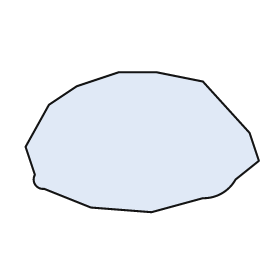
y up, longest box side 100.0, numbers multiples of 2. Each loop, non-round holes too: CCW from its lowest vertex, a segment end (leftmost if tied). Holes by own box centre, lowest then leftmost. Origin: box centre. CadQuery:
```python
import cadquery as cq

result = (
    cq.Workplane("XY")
    .moveTo(4.0, -30.0)
    .lineTo(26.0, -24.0)
    .threePointArc((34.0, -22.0), (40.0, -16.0))
    .lineTo(50.0, -8.0)
    .lineTo(46.0, 4.0)
    .lineTo(26.0, 26.0)
    .lineTo(6.0, 30.0)
    .lineTo(-10.0, 30.0)
    .lineTo(-28.0, 24.0)
    .lineTo(-40.0, 16.0)
    .lineTo(-50.0, -2.0)
    .lineTo(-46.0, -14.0)
    .threePointArc((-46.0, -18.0), (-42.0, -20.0))
    .lineTo(-22.0, -28.0)
    .close()
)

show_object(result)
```